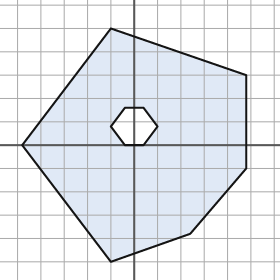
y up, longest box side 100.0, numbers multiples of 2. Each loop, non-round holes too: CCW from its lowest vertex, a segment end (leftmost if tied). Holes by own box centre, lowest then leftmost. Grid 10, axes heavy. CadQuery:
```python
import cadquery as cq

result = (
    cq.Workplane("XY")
    .moveTo(-10.0, -50.0)
    .lineTo(24.0, -38.0)
    .lineTo(48.0, -10.0)
    .lineTo(48.0, 30.0)
    .lineTo(-10.0, 50.0)
    .lineTo(-48.0, 0.0)
    .close()
    .moveTo(-4.0, 0.0)
    .lineTo(4.0, 0.0)
    .lineTo(10.0, 8.0)
    .lineTo(4.0, 16.0)
    .lineTo(-4.0, 16.0)
    .lineTo(-10.0, 8.0)
    .close()
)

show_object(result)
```